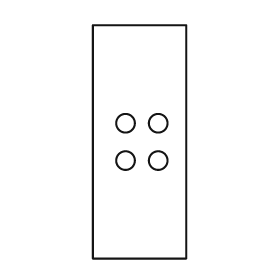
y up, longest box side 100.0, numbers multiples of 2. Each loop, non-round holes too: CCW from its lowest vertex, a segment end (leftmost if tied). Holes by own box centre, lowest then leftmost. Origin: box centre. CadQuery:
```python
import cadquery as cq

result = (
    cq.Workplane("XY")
    .moveTo(-20.0, -50.0)
    .lineTo(20.0, -50.0)
    .lineTo(20.0, 50.0)
    .lineTo(-20.0, 50.0)
    .close()
    .moveTo(-6.0, -8.0)
    .circle(4.0)
    .moveTo(8.0, -8.0)
    .circle(4.0)
    .moveTo(-6.0, 8.0)
    .circle(4.0)
    .moveTo(8.0, 8.0)
    .circle(4.0)
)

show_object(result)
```